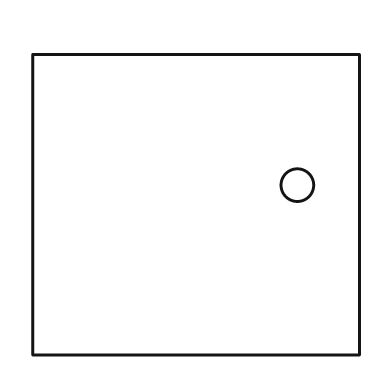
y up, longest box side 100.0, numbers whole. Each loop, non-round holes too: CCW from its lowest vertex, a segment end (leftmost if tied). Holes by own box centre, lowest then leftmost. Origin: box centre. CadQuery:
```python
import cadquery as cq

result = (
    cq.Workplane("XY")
    .moveTo(-50.0, -46.0)
    .lineTo(50.0, -46.0)
    .lineTo(50.0, 46.0)
    .lineTo(-50.0, 46.0)
    .close()
    .moveTo(31.0, 6.0)
    .circle(5.0)
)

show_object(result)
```